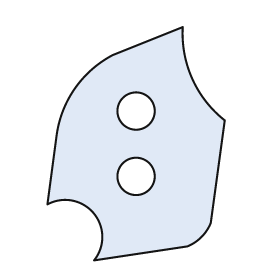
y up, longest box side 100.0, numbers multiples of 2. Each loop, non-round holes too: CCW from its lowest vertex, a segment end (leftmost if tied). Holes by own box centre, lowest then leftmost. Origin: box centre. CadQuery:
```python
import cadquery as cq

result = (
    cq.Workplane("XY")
    .moveTo(-18.0, -50.0)
    .lineTo(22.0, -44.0)
    .threePointArc((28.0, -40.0), (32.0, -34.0))
    .lineTo(38.0, 10.0)
    .threePointArc((24.0, 28.0), (20.0, 50.0))
    .lineTo(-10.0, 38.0)
    .threePointArc((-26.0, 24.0), (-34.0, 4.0))
    .lineTo(-38.0, -26.0)
    .threePointArc((-18.0, -30.0), (-18.0, -50.0))
    .close()
    .moveTo(0.0, -14.0)
    .circle(8.0)
    .moveTo(0.0, 14.0)
    .circle(8.0)
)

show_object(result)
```